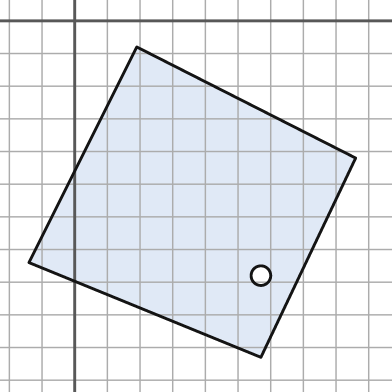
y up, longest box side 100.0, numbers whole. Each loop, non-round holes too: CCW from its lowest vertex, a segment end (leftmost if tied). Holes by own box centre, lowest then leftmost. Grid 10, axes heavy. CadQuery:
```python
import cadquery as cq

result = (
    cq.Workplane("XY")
    .moveTo(57.0, -103.0)
    .lineTo(86.0, -42.0)
    .lineTo(19.0, -8.0)
    .lineTo(-14.0, -74.0)
    .close()
    .moveTo(57.0, -78.0)
    .circle(3.0)
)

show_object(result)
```